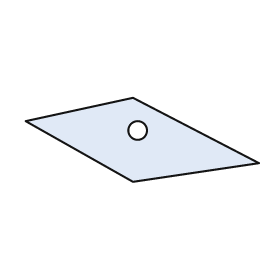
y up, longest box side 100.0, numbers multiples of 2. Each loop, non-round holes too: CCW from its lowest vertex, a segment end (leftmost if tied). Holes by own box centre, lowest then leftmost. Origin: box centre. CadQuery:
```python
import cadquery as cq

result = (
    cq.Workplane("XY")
    .moveTo(-4.0, -18.0)
    .lineTo(50.0, -10.0)
    .lineTo(-4.0, 18.0)
    .lineTo(-50.0, 8.0)
    .close()
    .moveTo(-2.0, 4.0)
    .circle(4.0)
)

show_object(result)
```